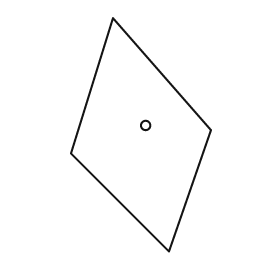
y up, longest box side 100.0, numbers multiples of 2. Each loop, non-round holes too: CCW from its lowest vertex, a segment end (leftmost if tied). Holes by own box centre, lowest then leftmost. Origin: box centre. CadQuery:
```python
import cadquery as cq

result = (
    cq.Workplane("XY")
    .moveTo(12.0, -50.0)
    .lineTo(30.0, 2.0)
    .lineTo(-12.0, 50.0)
    .lineTo(-30.0, -8.0)
    .close()
    .moveTo(2.0, 4.0)
    .circle(2.0)
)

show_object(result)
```